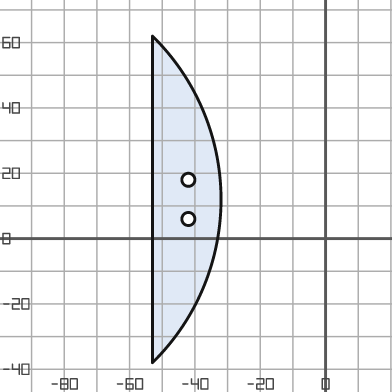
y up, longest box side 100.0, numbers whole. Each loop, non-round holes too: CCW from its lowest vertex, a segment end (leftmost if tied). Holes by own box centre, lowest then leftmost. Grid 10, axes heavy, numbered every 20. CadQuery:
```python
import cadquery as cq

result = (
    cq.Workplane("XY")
    .moveTo(-53.0, -38.0)
    .threePointArc((-32.0, 12.0), (-53.0, 62.0))
    .close()
    .moveTo(-42.0, 6.0)
    .circle(2.0)
    .moveTo(-42.0, 18.0)
    .circle(2.0)
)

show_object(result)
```